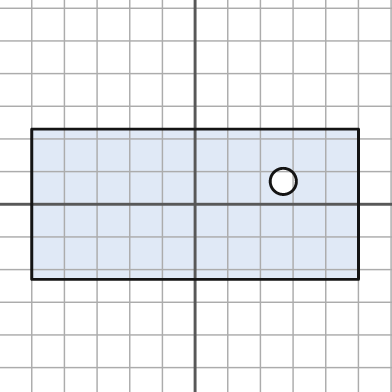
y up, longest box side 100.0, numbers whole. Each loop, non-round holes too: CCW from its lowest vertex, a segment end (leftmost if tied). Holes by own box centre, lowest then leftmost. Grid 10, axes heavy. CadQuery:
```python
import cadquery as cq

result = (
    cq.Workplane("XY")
    .moveTo(-50.0, -23.0)
    .lineTo(50.0, -23.0)
    .lineTo(50.0, 23.0)
    .lineTo(-50.0, 23.0)
    .close()
    .moveTo(27.0, 7.0)
    .circle(4.0)
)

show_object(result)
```